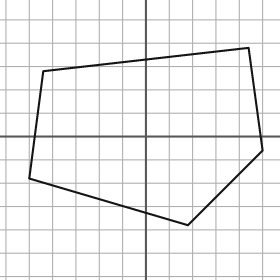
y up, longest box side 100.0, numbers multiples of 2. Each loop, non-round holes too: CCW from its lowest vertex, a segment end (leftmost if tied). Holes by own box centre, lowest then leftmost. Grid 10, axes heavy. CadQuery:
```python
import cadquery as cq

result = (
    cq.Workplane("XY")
    .moveTo(18.0, -38.0)
    .lineTo(50.0, -6.0)
    .lineTo(44.0, 38.0)
    .lineTo(-44.0, 28.0)
    .lineTo(-50.0, -18.0)
    .close()
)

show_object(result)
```